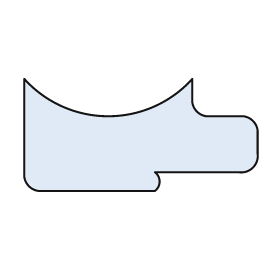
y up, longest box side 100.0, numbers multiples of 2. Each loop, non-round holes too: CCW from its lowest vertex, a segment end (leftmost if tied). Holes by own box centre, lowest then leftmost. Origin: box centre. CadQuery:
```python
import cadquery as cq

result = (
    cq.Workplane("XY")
    .moveTo(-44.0, -24.0)
    .lineTo(6.0, -24.0)
    .threePointArc((8.0, -20.0), (6.0, -16.0))
    .lineTo(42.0, -16.0)
    .threePointArc((48.0, -14.0), (50.0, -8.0))
    .lineTo(50.0, 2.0)
    .threePointArc((48.0, 6.0), (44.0, 8.0))
    .lineTo(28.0, 8.0)
    .threePointArc((24.0, 10.0), (22.0, 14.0))
    .lineTo(22.0, 24.0)
    .threePointArc((-14.0, 8.0), (-50.0, 24.0))
    .lineTo(-50.0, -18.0)
    .threePointArc((-48.0, -22.0), (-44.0, -24.0))
    .close()
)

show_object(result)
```